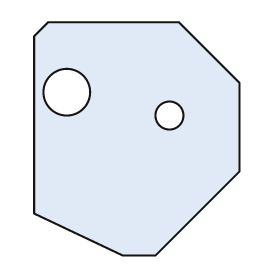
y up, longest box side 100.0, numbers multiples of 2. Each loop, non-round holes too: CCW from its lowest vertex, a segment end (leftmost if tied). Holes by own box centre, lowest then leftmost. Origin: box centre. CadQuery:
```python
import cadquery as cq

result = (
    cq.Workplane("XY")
    .moveTo(-6.0, -50.0)
    .lineTo(8.0, -50.0)
    .lineTo(44.0, -14.0)
    .lineTo(44.0, 24.0)
    .lineTo(18.0, 50.0)
    .lineTo(-38.0, 50.0)
    .lineTo(-44.0, 44.0)
    .lineTo(-44.0, -32.0)
    .close()
    .moveTo(14.0, 10.0)
    .circle(6.0)
    .moveTo(-30.0, 20.0)
    .circle(10.0)
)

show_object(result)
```